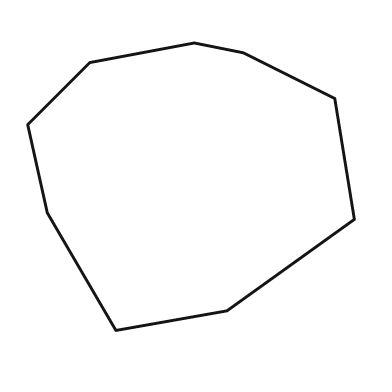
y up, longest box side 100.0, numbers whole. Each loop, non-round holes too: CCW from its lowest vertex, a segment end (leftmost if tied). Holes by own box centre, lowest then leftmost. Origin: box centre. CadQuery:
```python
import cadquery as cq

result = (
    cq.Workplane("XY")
    .moveTo(-23.0, -44.0)
    .lineTo(11.0, -38.0)
    .lineTo(50.0, -10.0)
    .lineTo(44.0, 27.0)
    .lineTo(16.0, 41.0)
    .lineTo(1.0, 44.0)
    .lineTo(-31.0, 38.0)
    .lineTo(-50.0, 19.0)
    .lineTo(-44.0, -8.0)
    .close()
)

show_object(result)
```